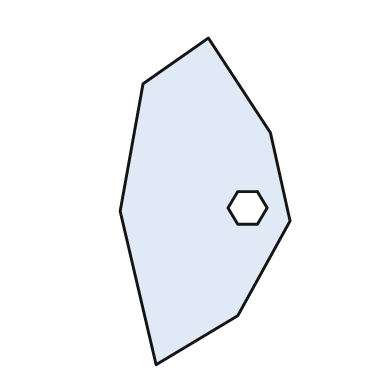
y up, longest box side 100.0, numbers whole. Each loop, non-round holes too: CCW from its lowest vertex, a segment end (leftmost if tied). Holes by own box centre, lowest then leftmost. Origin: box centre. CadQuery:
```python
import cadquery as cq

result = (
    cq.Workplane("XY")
    .moveTo(-15.0, -50.0)
    .lineTo(10.0, -35.0)
    .lineTo(26.0, -6.0)
    .lineTo(20.0, 21.0)
    .lineTo(1.0, 50.0)
    .lineTo(-19.0, 36.0)
    .lineTo(-26.0, -3.0)
    .close()
    .moveTo(10.0, -7.0)
    .lineTo(16.0, -7.0)
    .lineTo(19.0, -2.0)
    .lineTo(16.0, 3.0)
    .lineTo(10.0, 3.0)
    .lineTo(7.0, -2.0)
    .close()
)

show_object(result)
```